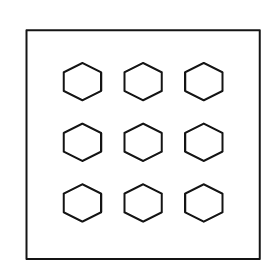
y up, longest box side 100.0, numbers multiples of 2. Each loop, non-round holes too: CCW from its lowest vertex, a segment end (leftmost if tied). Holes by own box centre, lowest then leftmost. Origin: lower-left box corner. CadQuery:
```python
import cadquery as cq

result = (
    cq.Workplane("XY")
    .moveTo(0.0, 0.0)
    .lineTo(100.0, 0.0)
    .lineTo(100.0, 98.0)
    .lineTo(0.0, 98.0)
    .close()
    .moveTo(24.0, 16.0)
    .lineTo(32.0, 20.0)
    .lineTo(32.0, 28.0)
    .lineTo(24.0, 32.0)
    .lineTo(16.0, 28.0)
    .lineTo(16.0, 20.0)
    .close()
    .moveTo(50.0, 16.0)
    .lineTo(58.0, 20.0)
    .lineTo(58.0, 28.0)
    .lineTo(50.0, 32.0)
    .lineTo(42.0, 28.0)
    .lineTo(42.0, 20.0)
    .close()
    .moveTo(76.0, 16.0)
    .lineTo(84.0, 20.0)
    .lineTo(84.0, 28.0)
    .lineTo(76.0, 32.0)
    .lineTo(68.0, 28.0)
    .lineTo(68.0, 20.0)
    .close()
    .moveTo(24.0, 42.0)
    .lineTo(32.0, 46.0)
    .lineTo(32.0, 54.0)
    .lineTo(24.0, 58.0)
    .lineTo(16.0, 54.0)
    .lineTo(16.0, 46.0)
    .close()
    .moveTo(50.0, 42.0)
    .lineTo(58.0, 46.0)
    .lineTo(58.0, 54.0)
    .lineTo(50.0, 58.0)
    .lineTo(42.0, 54.0)
    .lineTo(42.0, 46.0)
    .close()
    .moveTo(76.0, 42.0)
    .lineTo(84.0, 46.0)
    .lineTo(84.0, 54.0)
    .lineTo(76.0, 58.0)
    .lineTo(68.0, 54.0)
    .lineTo(68.0, 46.0)
    .close()
    .moveTo(24.0, 68.0)
    .lineTo(32.0, 72.0)
    .lineTo(32.0, 80.0)
    .lineTo(24.0, 84.0)
    .lineTo(16.0, 80.0)
    .lineTo(16.0, 72.0)
    .close()
    .moveTo(50.0, 68.0)
    .lineTo(58.0, 72.0)
    .lineTo(58.0, 80.0)
    .lineTo(50.0, 84.0)
    .lineTo(42.0, 80.0)
    .lineTo(42.0, 72.0)
    .close()
    .moveTo(76.0, 68.0)
    .lineTo(84.0, 72.0)
    .lineTo(84.0, 80.0)
    .lineTo(76.0, 84.0)
    .lineTo(68.0, 80.0)
    .lineTo(68.0, 72.0)
    .close()
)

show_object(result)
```